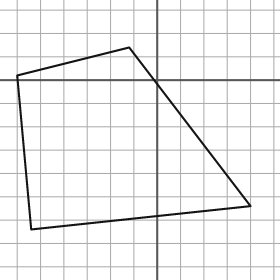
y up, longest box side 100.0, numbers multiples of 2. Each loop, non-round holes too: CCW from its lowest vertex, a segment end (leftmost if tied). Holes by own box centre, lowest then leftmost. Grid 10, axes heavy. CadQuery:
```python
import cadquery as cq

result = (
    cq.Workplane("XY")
    .moveTo(-54.0, -64.0)
    .lineTo(40.0, -54.0)
    .lineTo(-12.0, 14.0)
    .lineTo(-60.0, 2.0)
    .close()
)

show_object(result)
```